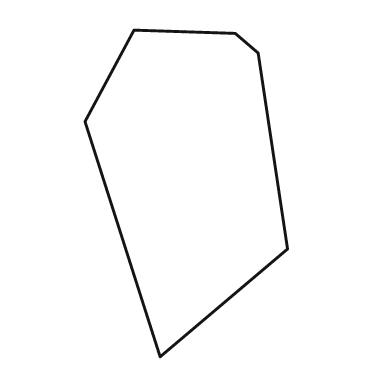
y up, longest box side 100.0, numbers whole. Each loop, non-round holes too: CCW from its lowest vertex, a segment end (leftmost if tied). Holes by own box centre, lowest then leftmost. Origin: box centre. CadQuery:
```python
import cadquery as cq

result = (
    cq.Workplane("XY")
    .moveTo(-8.0, -50.0)
    .lineTo(31.0, -17.0)
    .lineTo(22.0, 43.0)
    .lineTo(15.0, 49.0)
    .lineTo(-16.0, 50.0)
    .lineTo(-31.0, 22.0)
    .close()
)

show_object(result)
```